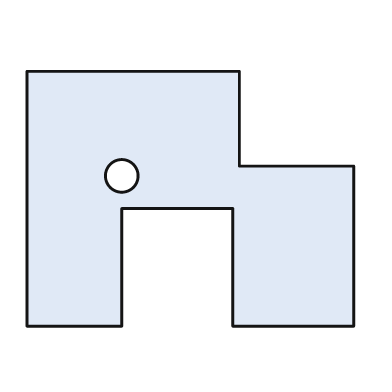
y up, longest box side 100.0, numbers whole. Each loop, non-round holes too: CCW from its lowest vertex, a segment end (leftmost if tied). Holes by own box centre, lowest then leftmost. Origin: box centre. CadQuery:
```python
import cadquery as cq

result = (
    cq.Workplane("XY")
    .moveTo(-50.0, -39.0)
    .lineTo(-21.0, -39.0)
    .lineTo(-21.0, -3.0)
    .lineTo(13.0, -3.0)
    .lineTo(13.0, -39.0)
    .lineTo(50.0, -39.0)
    .lineTo(50.0, 10.0)
    .lineTo(15.0, 10.0)
    .lineTo(15.0, 39.0)
    .lineTo(-50.0, 39.0)
    .close()
    .moveTo(-21.0, 7.0)
    .circle(5.0)
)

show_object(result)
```